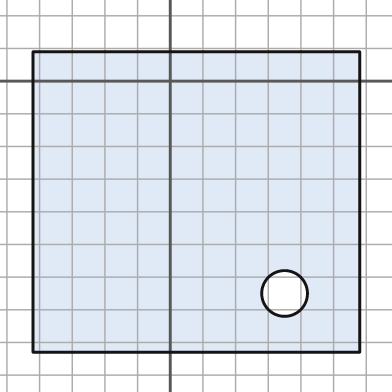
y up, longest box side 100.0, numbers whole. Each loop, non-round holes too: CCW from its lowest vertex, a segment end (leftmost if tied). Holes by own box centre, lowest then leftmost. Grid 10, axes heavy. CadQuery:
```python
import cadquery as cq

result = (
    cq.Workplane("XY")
    .moveTo(-42.0, -83.0)
    .lineTo(58.0, -83.0)
    .lineTo(58.0, 9.0)
    .lineTo(-42.0, 9.0)
    .close()
    .moveTo(35.0, -65.0)
    .circle(7.0)
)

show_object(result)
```